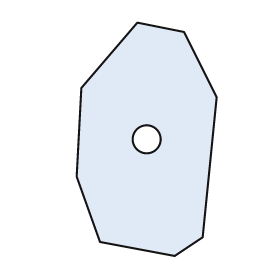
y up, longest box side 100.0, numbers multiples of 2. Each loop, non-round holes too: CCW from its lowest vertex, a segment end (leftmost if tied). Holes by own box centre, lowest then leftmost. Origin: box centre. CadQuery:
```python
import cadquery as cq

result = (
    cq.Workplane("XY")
    .moveTo(12.0, -50.0)
    .lineTo(24.0, -42.0)
    .lineTo(30.0, 18.0)
    .lineTo(16.0, 46.0)
    .lineTo(-4.0, 50.0)
    .lineTo(-28.0, 22.0)
    .lineTo(-30.0, -16.0)
    .lineTo(-20.0, -44.0)
    .close()
    .moveTo(0.0, 0.0)
    .circle(6.0)
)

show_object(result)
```